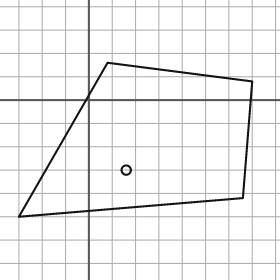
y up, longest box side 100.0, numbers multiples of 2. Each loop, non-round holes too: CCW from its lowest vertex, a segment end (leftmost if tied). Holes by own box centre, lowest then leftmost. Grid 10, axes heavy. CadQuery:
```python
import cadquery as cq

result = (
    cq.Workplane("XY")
    .moveTo(-30.0, -50.0)
    .lineTo(66.0, -42.0)
    .lineTo(70.0, 8.0)
    .lineTo(8.0, 16.0)
    .close()
    .moveTo(16.0, -30.0)
    .circle(2.0)
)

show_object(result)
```